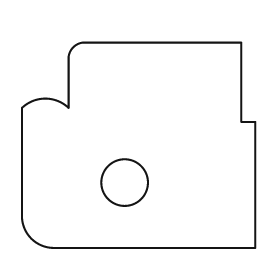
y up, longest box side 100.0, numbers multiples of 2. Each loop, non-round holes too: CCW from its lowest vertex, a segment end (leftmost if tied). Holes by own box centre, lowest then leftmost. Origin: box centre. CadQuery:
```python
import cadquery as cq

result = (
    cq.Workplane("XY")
    .moveTo(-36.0, -44.0)
    .lineTo(50.0, -44.0)
    .lineTo(50.0, 10.0)
    .lineTo(44.0, 10.0)
    .lineTo(44.0, 44.0)
    .lineTo(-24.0, 44.0)
    .threePointArc((-28.0, 42.0), (-30.0, 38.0))
    .lineTo(-30.0, 16.0)
    .threePointArc((-40.0, 20.0), (-50.0, 16.0))
    .lineTo(-50.0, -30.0)
    .threePointArc((-46.0, -40.0), (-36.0, -44.0))
    .close()
    .moveTo(-6.0, -16.0)
    .circle(10.0)
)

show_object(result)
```